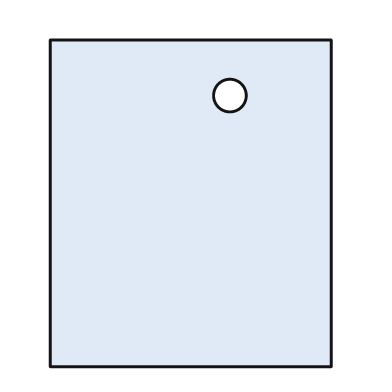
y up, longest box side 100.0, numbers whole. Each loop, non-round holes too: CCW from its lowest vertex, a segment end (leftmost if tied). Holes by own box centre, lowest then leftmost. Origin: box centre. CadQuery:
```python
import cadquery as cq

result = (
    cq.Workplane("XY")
    .moveTo(-43.0, -50.0)
    .lineTo(43.0, -50.0)
    .lineTo(43.0, 50.0)
    .lineTo(-43.0, 50.0)
    .close()
    .moveTo(12.0, 33.0)
    .circle(5.0)
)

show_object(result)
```